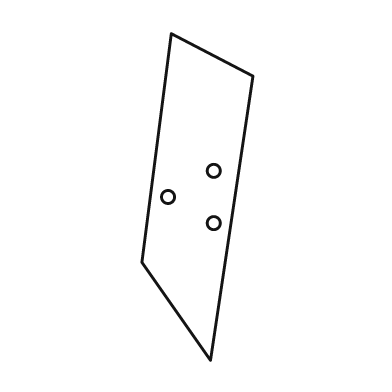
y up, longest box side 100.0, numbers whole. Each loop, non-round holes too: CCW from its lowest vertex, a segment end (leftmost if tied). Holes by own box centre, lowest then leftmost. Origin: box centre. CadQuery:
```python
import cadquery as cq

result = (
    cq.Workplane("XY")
    .moveTo(4.0, -50.0)
    .lineTo(17.0, 37.0)
    .lineTo(-8.0, 50.0)
    .lineTo(-17.0, -20.0)
    .close()
    .moveTo(5.0, -8.0)
    .circle(2.0)
    .moveTo(-9.0, 0.0)
    .circle(2.0)
    .moveTo(5.0, 8.0)
    .circle(2.0)
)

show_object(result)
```